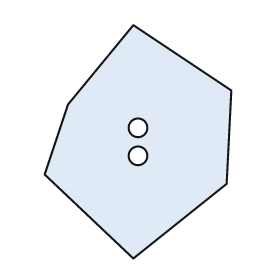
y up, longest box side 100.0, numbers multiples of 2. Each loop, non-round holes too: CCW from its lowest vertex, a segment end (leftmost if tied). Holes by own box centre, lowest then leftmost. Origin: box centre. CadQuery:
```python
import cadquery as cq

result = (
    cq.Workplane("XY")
    .moveTo(-2.0, -50.0)
    .lineTo(38.0, -18.0)
    .lineTo(40.0, 22.0)
    .lineTo(-2.0, 50.0)
    .lineTo(-30.0, 16.0)
    .lineTo(-40.0, -14.0)
    .close()
    .moveTo(0.0, -6.0)
    .circle(4.0)
    .moveTo(0.0, 6.0)
    .circle(4.0)
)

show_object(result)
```